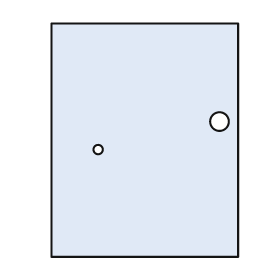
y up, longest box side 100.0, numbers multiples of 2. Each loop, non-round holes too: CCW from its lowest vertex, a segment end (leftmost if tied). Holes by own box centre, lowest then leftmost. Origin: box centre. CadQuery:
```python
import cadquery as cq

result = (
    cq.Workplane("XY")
    .moveTo(-40.0, -50.0)
    .lineTo(40.0, -50.0)
    .lineTo(40.0, 50.0)
    .lineTo(-40.0, 50.0)
    .close()
    .moveTo(-20.0, -4.0)
    .circle(2.0)
    .moveTo(32.0, 8.0)
    .circle(4.0)
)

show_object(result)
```